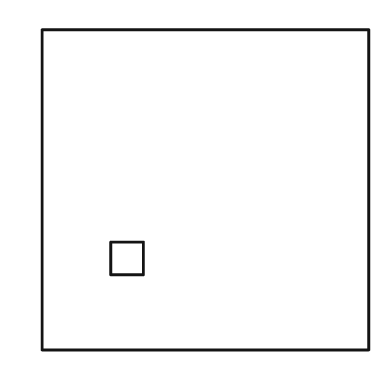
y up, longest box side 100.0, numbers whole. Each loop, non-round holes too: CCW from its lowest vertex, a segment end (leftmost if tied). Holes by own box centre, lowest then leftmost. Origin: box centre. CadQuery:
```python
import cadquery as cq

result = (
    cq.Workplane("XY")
    .moveTo(-50.0, -49.0)
    .lineTo(50.0, -49.0)
    .lineTo(50.0, 49.0)
    .lineTo(-50.0, 49.0)
    .close()
    .moveTo(-29.0, -26.0)
    .lineTo(-19.0, -26.0)
    .lineTo(-19.0, -16.0)
    .lineTo(-29.0, -16.0)
    .close()
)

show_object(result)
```